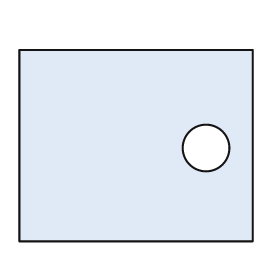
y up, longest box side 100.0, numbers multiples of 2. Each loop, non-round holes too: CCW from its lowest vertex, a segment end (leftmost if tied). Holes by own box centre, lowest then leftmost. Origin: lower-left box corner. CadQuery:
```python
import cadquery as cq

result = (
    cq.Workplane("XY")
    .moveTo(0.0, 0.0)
    .lineTo(100.0, 0.0)
    .lineTo(100.0, 82.0)
    .lineTo(0.0, 82.0)
    .close()
    .moveTo(80.0, 40.0)
    .circle(10.0)
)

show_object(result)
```